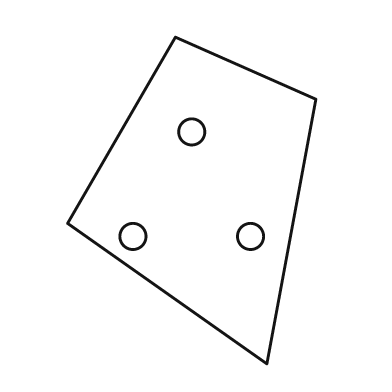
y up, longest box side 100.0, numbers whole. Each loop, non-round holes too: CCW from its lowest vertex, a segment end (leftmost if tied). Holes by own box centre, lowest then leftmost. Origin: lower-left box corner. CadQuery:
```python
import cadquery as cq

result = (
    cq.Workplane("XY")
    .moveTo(61.0, 0.0)
    .lineTo(76.0, 81.0)
    .lineTo(33.0, 100.0)
    .lineTo(0.0, 43.0)
    .close()
    .moveTo(20.0, 39.0)
    .circle(4.0)
    .moveTo(56.0, 39.0)
    .circle(4.0)
    .moveTo(38.0, 71.0)
    .circle(4.0)
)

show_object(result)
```